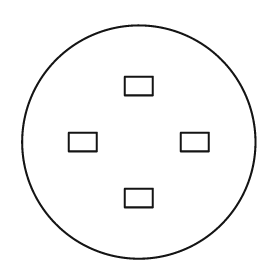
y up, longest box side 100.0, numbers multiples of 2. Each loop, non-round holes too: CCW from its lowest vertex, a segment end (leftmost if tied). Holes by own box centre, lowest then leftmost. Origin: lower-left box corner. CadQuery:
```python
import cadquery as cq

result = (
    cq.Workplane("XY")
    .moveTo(50.0, 50.0)
    .circle(50.0)
    .moveTo(44.0, 22.0)
    .lineTo(56.0, 22.0)
    .lineTo(56.0, 30.0)
    .lineTo(44.0, 30.0)
    .close()
    .moveTo(20.0, 46.0)
    .lineTo(32.0, 46.0)
    .lineTo(32.0, 54.0)
    .lineTo(20.0, 54.0)
    .close()
    .moveTo(68.0, 46.0)
    .lineTo(80.0, 46.0)
    .lineTo(80.0, 54.0)
    .lineTo(68.0, 54.0)
    .close()
    .moveTo(44.0, 70.0)
    .lineTo(56.0, 70.0)
    .lineTo(56.0, 78.0)
    .lineTo(44.0, 78.0)
    .close()
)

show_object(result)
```